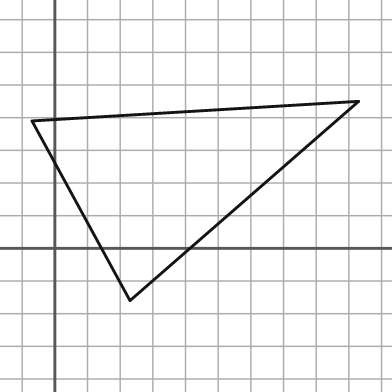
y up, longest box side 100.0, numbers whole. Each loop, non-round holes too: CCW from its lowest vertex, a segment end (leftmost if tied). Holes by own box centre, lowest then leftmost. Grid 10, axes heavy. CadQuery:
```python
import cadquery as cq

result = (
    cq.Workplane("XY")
    .moveTo(23.0, -16.0)
    .lineTo(93.0, 45.0)
    .lineTo(-7.0, 39.0)
    .close()
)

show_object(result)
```